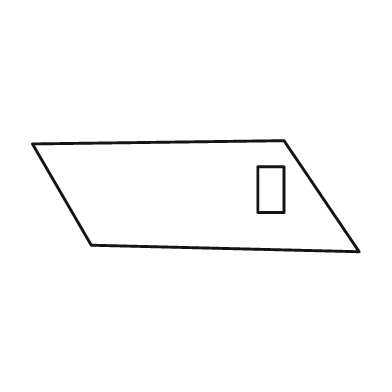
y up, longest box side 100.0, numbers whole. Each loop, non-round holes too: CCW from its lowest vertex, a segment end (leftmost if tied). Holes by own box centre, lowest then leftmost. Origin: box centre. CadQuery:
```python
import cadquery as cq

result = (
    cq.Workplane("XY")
    .moveTo(50.0, -17.0)
    .lineTo(27.0, 17.0)
    .lineTo(-50.0, 16.0)
    .lineTo(-32.0, -15.0)
    .close()
    .moveTo(19.0, -5.0)
    .lineTo(27.0, -5.0)
    .lineTo(27.0, 9.0)
    .lineTo(19.0, 9.0)
    .close()
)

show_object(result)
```